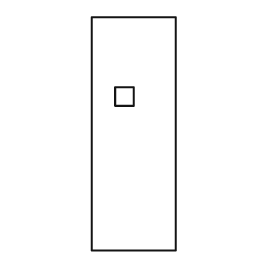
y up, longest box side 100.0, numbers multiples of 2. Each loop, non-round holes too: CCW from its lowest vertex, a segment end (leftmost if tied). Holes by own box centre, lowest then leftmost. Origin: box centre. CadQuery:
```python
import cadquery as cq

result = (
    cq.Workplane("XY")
    .moveTo(-18.0, -50.0)
    .lineTo(18.0, -50.0)
    .lineTo(18.0, 50.0)
    .lineTo(-18.0, 50.0)
    .close()
    .moveTo(-8.0, 12.0)
    .lineTo(0.0, 12.0)
    .lineTo(0.0, 20.0)
    .lineTo(-8.0, 20.0)
    .close()
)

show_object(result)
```